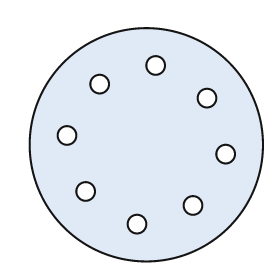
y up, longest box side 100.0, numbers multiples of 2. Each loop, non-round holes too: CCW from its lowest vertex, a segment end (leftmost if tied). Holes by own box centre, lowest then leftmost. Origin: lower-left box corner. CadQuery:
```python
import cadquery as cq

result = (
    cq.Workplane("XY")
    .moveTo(50.0, 50.0)
    .circle(50.0)
    .moveTo(46.0, 16.0)
    .circle(4.0)
    .moveTo(70.0, 24.0)
    .circle(4.0)
    .moveTo(24.0, 30.0)
    .circle(4.0)
    .moveTo(84.0, 46.0)
    .circle(4.0)
    .moveTo(16.0, 54.0)
    .circle(4.0)
    .moveTo(76.0, 70.0)
    .circle(4.0)
    .moveTo(30.0, 76.0)
    .circle(4.0)
    .moveTo(54.0, 84.0)
    .circle(4.0)
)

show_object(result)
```